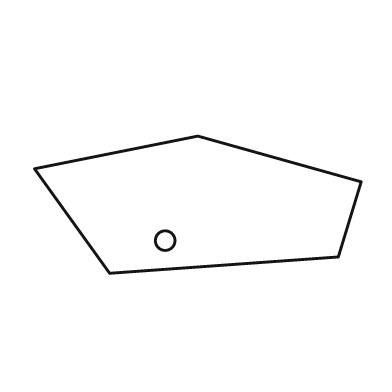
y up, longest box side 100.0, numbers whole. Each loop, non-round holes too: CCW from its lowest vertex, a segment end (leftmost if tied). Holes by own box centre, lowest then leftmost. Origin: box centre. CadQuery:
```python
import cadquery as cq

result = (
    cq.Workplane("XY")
    .moveTo(-27.0, -21.0)
    .lineTo(43.0, -16.0)
    .lineTo(50.0, 7.0)
    .lineTo(0.0, 21.0)
    .lineTo(-50.0, 11.0)
    .close()
    .moveTo(-10.0, -11.0)
    .circle(3.0)
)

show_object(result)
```